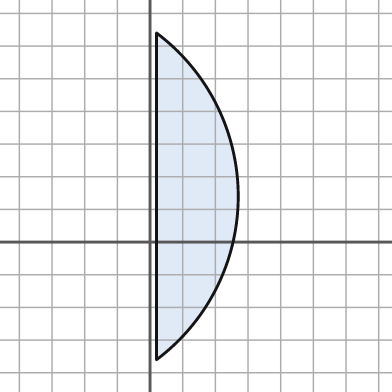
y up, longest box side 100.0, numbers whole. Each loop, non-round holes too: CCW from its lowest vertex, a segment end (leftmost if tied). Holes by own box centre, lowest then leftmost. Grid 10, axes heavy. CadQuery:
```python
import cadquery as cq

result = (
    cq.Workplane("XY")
    .moveTo(2.0, -36.0)
    .threePointArc((27.0, 14.0), (2.0, 64.0))
    .close()
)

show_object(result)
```